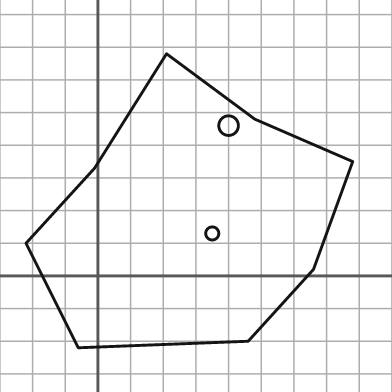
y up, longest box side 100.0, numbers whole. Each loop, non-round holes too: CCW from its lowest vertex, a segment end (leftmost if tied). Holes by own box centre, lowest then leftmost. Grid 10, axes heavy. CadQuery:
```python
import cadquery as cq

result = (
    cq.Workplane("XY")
    .moveTo(-6.0, -22.0)
    .lineTo(46.0, -20.0)
    .lineTo(66.0, 2.0)
    .lineTo(78.0, 35.0)
    .lineTo(48.0, 48.0)
    .lineTo(21.0, 68.0)
    .lineTo(-1.0, 33.0)
    .lineTo(-22.0, 10.0)
    .close()
    .moveTo(35.0, 13.0)
    .circle(2.0)
    .moveTo(40.0, 46.0)
    .circle(3.0)
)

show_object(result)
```